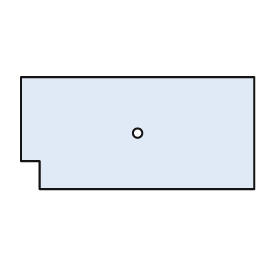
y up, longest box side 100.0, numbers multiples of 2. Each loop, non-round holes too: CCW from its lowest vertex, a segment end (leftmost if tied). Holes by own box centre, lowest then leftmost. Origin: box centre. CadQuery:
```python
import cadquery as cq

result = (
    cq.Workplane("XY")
    .moveTo(-42.0, -24.0)
    .lineTo(50.0, -24.0)
    .lineTo(50.0, 24.0)
    .lineTo(-50.0, 24.0)
    .lineTo(-50.0, -12.0)
    .lineTo(-42.0, -12.0)
    .close()
    .moveTo(0.0, 0.0)
    .circle(2.0)
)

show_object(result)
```